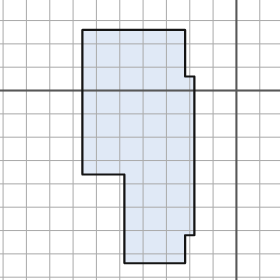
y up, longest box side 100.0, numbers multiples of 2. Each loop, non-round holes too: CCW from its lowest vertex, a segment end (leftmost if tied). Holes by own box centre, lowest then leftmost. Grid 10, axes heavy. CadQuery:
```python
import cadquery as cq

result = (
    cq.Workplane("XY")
    .moveTo(-48.0, -74.0)
    .lineTo(-22.0, -74.0)
    .lineTo(-22.0, -62.0)
    .lineTo(-18.0, -62.0)
    .lineTo(-18.0, 6.0)
    .lineTo(-22.0, 6.0)
    .lineTo(-22.0, 26.0)
    .lineTo(-66.0, 26.0)
    .lineTo(-66.0, -36.0)
    .lineTo(-48.0, -36.0)
    .close()
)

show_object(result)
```